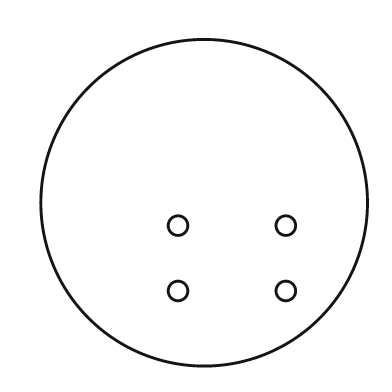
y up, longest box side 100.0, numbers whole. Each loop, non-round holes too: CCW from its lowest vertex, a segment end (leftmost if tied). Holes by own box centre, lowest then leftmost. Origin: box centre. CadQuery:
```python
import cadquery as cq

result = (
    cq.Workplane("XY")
    .moveTo(0.0, 0.0)
    .circle(50.0)
    .moveTo(-8.0, -27.0)
    .circle(3.0)
    .moveTo(25.0, -27.0)
    .circle(3.0)
    .moveTo(-8.0, -7.0)
    .circle(3.0)
    .moveTo(25.0, -7.0)
    .circle(3.0)
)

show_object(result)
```